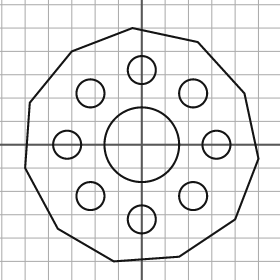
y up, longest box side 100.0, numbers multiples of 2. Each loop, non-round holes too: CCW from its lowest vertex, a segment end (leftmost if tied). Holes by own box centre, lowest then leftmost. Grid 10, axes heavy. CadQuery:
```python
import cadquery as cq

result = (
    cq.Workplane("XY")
    .moveTo(-12.0, -50.0)
    .lineTo(16.0, -48.0)
    .lineTo(40.0, -32.0)
    .lineTo(50.0, -6.0)
    .lineTo(44.0, 22.0)
    .lineTo(24.0, 44.0)
    .lineTo(-4.0, 50.0)
    .lineTo(-30.0, 40.0)
    .lineTo(-48.0, 18.0)
    .lineTo(-50.0, -10.0)
    .lineTo(-36.0, -36.0)
    .close()
    .moveTo(0.0, -32.0)
    .circle(6.0)
    .moveTo(-22.0, -22.0)
    .circle(6.0)
    .moveTo(22.0, -22.0)
    .circle(6.0)
    .moveTo(-32.0, 0.0)
    .circle(6.0)
    .moveTo(0.0, 0.0)
    .circle(16.0)
    .moveTo(32.0, 0.0)
    .circle(6.0)
    .moveTo(-22.0, 22.0)
    .circle(6.0)
    .moveTo(22.0, 22.0)
    .circle(6.0)
    .moveTo(0.0, 32.0)
    .circle(6.0)
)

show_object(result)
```